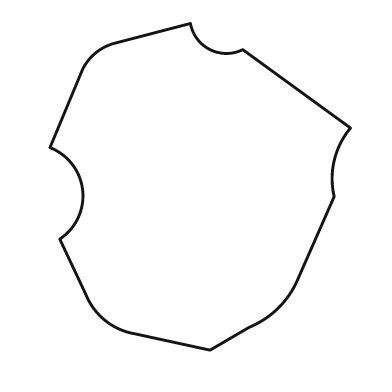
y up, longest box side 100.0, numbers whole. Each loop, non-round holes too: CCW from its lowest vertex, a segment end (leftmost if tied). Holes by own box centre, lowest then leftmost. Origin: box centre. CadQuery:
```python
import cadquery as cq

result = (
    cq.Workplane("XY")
    .moveTo(3.0, -50.0)
    .lineTo(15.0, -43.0)
    .threePointArc((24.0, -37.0), (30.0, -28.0))
    .lineTo(41.0, -3.0)
    .threePointArc((41.0, 8.0), (46.0, 18.0))
    .lineTo(13.0, 42.0)
    .threePointArc((3.0, 42.0), (-3.0, 50.0))
    .lineTo(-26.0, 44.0)
    .threePointArc((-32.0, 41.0), (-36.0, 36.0))
    .lineTo(-46.0, 12.0)
    .threePointArc((-36.0, -1.0), (-43.0, -16.0))
    .lineTo(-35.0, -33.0)
    .threePointArc((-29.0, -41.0), (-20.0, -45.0))
    .close()
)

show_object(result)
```